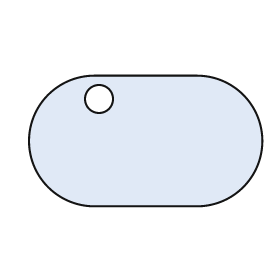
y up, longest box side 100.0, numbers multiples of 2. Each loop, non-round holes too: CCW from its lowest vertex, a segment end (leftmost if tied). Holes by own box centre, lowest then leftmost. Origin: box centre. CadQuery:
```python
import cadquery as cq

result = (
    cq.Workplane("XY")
    .moveTo(-22.0, -28.0)
    .lineTo(22.0, -28.0)
    .threePointArc((50.0, 0.0), (22.0, 28.0))
    .lineTo(-22.0, 28.0)
    .threePointArc((-50.0, 0.0), (-22.0, -28.0))
    .close()
    .moveTo(-20.0, 18.0)
    .circle(6.0)
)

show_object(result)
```